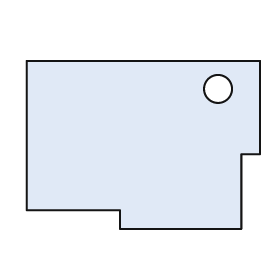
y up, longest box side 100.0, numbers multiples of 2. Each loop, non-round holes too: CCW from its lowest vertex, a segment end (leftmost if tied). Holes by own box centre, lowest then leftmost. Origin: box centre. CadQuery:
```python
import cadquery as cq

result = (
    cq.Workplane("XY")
    .moveTo(-10.0, -36.0)
    .lineTo(42.0, -36.0)
    .lineTo(42.0, -4.0)
    .lineTo(50.0, -4.0)
    .lineTo(50.0, 36.0)
    .lineTo(-50.0, 36.0)
    .lineTo(-50.0, -28.0)
    .lineTo(-10.0, -28.0)
    .close()
    .moveTo(32.0, 24.0)
    .circle(6.0)
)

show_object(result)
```